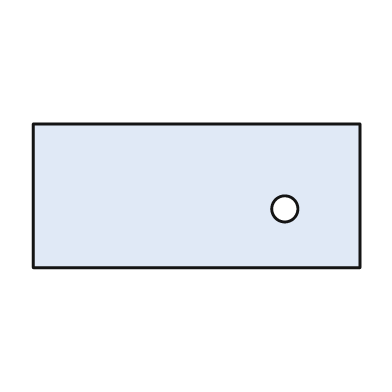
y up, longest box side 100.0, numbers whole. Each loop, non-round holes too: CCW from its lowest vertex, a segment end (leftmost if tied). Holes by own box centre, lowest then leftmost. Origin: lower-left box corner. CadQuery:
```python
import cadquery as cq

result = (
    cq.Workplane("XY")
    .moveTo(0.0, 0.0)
    .lineTo(100.0, 0.0)
    .lineTo(100.0, 44.0)
    .lineTo(0.0, 44.0)
    .close()
    .moveTo(77.0, 18.0)
    .circle(4.0)
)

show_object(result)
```